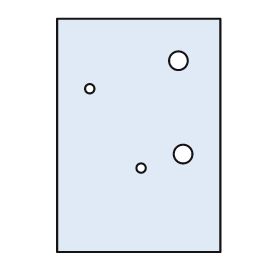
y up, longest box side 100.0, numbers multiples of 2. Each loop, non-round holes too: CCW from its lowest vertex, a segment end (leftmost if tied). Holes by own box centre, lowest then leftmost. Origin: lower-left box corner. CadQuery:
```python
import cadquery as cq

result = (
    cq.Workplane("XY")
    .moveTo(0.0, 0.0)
    .lineTo(70.0, 0.0)
    .lineTo(70.0, 100.0)
    .lineTo(0.0, 100.0)
    .close()
    .moveTo(36.0, 36.0)
    .circle(2.0)
    .moveTo(54.0, 42.0)
    .circle(4.0)
    .moveTo(14.0, 70.0)
    .circle(2.0)
    .moveTo(52.0, 82.0)
    .circle(4.0)
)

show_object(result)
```